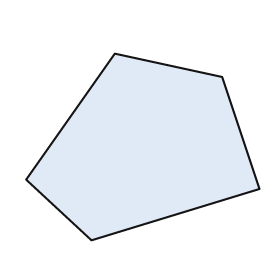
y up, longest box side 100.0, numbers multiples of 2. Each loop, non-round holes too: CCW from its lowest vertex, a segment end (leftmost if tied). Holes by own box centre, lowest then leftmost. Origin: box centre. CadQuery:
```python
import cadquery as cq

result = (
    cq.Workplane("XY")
    .moveTo(-22.0, -40.0)
    .lineTo(50.0, -18.0)
    .lineTo(34.0, 30.0)
    .lineTo(-12.0, 40.0)
    .lineTo(-50.0, -14.0)
    .close()
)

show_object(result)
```